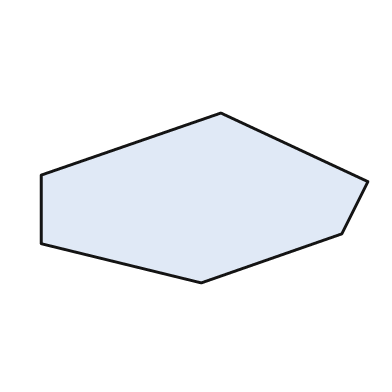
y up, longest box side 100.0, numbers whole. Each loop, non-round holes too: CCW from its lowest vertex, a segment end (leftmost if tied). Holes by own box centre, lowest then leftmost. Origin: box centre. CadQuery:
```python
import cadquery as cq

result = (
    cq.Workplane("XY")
    .moveTo(-1.0, -26.0)
    .lineTo(42.0, -11.0)
    .lineTo(50.0, 5.0)
    .lineTo(5.0, 26.0)
    .lineTo(-50.0, 7.0)
    .lineTo(-50.0, -14.0)
    .close()
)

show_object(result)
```